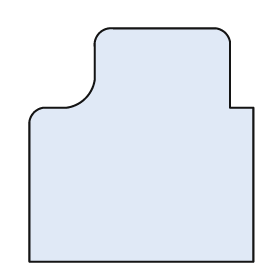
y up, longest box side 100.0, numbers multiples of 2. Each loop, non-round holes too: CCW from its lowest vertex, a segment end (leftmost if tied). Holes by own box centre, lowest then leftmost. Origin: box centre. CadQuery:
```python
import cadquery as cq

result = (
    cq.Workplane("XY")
    .moveTo(-48.0, -50.0)
    .lineTo(48.0, -50.0)
    .lineTo(48.0, 16.0)
    .lineTo(38.0, 16.0)
    .lineTo(38.0, 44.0)
    .threePointArc((36.0, 48.0), (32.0, 50.0))
    .lineTo(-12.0, 50.0)
    .threePointArc((-18.0, 48.0), (-20.0, 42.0))
    .lineTo(-20.0, 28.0)
    .threePointArc((-24.0, 20.0), (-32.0, 16.0))
    .lineTo(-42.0, 16.0)
    .threePointArc((-46.0, 14.0), (-48.0, 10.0))
    .close()
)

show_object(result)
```